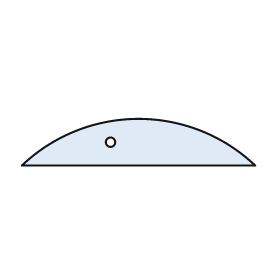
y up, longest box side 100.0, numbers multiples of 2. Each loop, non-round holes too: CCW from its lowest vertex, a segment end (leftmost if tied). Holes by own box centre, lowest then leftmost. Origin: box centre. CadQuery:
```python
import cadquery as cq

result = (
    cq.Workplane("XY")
    .moveTo(-50.0, -10.0)
    .lineTo(50.0, -10.0)
    .threePointArc((0.0, 10.0), (-50.0, -10.0))
    .close()
    .moveTo(-12.0, 0.0)
    .circle(2.0)
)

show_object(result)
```